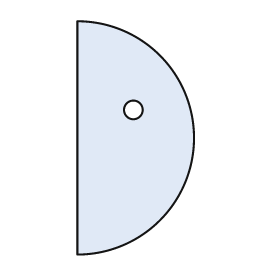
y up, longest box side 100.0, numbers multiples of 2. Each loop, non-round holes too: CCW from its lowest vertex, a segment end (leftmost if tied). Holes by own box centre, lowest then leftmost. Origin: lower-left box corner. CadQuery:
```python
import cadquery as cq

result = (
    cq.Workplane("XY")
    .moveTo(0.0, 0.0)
    .threePointArc((50.0, 50.0), (0.0, 100.0))
    .close()
    .moveTo(24.0, 62.0)
    .circle(4.0)
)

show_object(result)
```